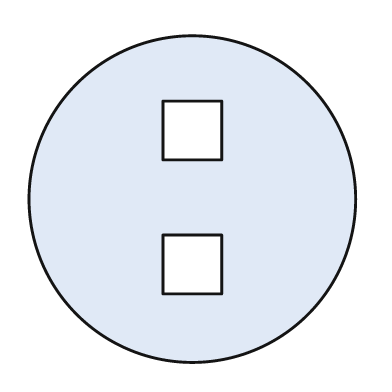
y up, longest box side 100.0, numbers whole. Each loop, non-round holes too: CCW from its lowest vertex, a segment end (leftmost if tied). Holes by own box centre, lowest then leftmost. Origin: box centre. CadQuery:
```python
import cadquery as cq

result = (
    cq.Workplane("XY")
    .moveTo(0.0, 0.0)
    .circle(50.0)
    .moveTo(-9.0, -29.0)
    .lineTo(9.0, -29.0)
    .lineTo(9.0, -11.0)
    .lineTo(-9.0, -11.0)
    .close()
    .moveTo(-9.0, 12.0)
    .lineTo(9.0, 12.0)
    .lineTo(9.0, 30.0)
    .lineTo(-9.0, 30.0)
    .close()
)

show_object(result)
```